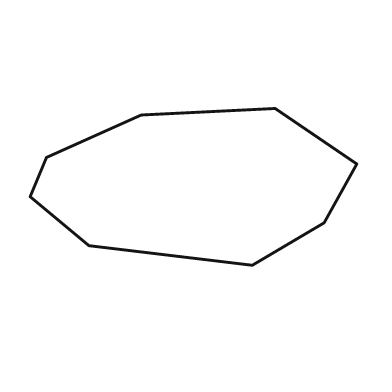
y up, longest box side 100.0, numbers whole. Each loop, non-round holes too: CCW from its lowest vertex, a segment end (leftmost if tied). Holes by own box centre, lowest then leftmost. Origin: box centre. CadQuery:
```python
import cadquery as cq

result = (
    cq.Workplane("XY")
    .moveTo(18.0, -24.0)
    .lineTo(40.0, -11.0)
    .lineTo(50.0, 7.0)
    .lineTo(25.0, 24.0)
    .lineTo(-16.0, 22.0)
    .lineTo(-45.0, 9.0)
    .lineTo(-50.0, -3.0)
    .lineTo(-32.0, -18.0)
    .close()
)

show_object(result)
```